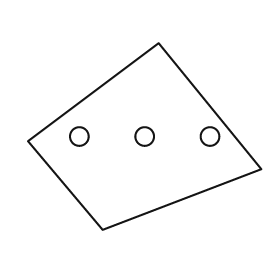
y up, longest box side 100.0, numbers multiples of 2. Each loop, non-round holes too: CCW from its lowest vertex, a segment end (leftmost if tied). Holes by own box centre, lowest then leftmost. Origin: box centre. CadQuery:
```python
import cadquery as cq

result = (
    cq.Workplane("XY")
    .moveTo(-18.0, -40.0)
    .lineTo(50.0, -14.0)
    .lineTo(6.0, 40.0)
    .lineTo(-50.0, -2.0)
    .close()
    .moveTo(-28.0, 0.0)
    .circle(4.0)
    .moveTo(0.0, 0.0)
    .circle(4.0)
    .moveTo(28.0, 0.0)
    .circle(4.0)
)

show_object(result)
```